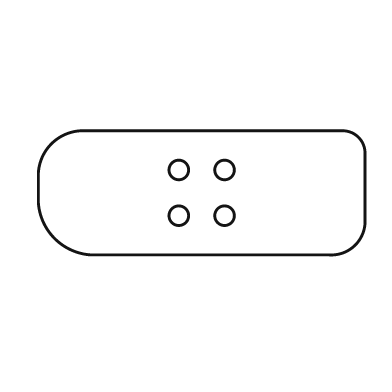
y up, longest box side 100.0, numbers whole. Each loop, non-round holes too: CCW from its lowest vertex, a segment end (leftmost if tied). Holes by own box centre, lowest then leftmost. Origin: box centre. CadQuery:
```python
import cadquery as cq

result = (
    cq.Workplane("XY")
    .moveTo(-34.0, -19.0)
    .lineTo(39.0, -19.0)
    .threePointArc((47.0, -16.0), (50.0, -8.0))
    .lineTo(50.0, 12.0)
    .threePointArc((48.0, 17.0), (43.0, 19.0))
    .lineTo(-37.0, 19.0)
    .threePointArc((-46.0, 15.0), (-50.0, 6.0))
    .lineTo(-50.0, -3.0)
    .threePointArc((-45.0, -14.0), (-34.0, -19.0))
    .close()
    .moveTo(-7.0, -7.0)
    .circle(3.0)
    .moveTo(7.0, -7.0)
    .circle(3.0)
    .moveTo(-7.0, 7.0)
    .circle(3.0)
    .moveTo(7.0, 7.0)
    .circle(3.0)
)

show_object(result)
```